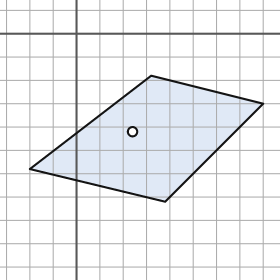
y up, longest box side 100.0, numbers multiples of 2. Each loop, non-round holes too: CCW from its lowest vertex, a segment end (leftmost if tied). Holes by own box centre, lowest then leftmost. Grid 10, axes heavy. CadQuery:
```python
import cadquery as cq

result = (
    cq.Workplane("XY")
    .moveTo(38.0, -72.0)
    .lineTo(80.0, -30.0)
    .lineTo(32.0, -18.0)
    .lineTo(-20.0, -58.0)
    .close()
    .moveTo(24.0, -42.0)
    .circle(2.0)
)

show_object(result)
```